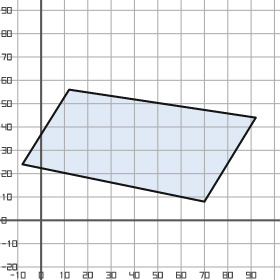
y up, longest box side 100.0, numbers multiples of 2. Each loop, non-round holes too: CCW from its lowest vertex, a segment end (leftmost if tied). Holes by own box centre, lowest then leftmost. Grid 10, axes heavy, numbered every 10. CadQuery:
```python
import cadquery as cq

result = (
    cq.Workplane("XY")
    .moveTo(70.0, 8.0)
    .lineTo(92.0, 44.0)
    .lineTo(12.0, 56.0)
    .lineTo(-8.0, 24.0)
    .close()
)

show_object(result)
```